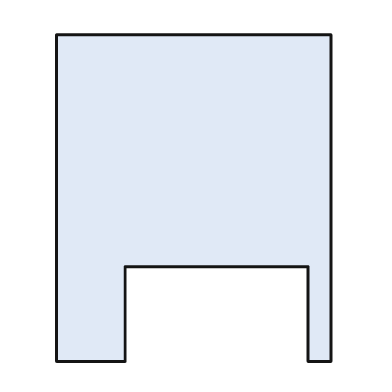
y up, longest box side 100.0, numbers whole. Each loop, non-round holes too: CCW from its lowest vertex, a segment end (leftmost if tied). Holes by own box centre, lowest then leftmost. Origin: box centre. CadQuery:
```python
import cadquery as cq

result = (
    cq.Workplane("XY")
    .moveTo(-42.0, -50.0)
    .lineTo(-21.0, -50.0)
    .lineTo(-21.0, -21.0)
    .lineTo(35.0, -21.0)
    .lineTo(35.0, -50.0)
    .lineTo(42.0, -50.0)
    .lineTo(42.0, 50.0)
    .lineTo(-42.0, 50.0)
    .close()
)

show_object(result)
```